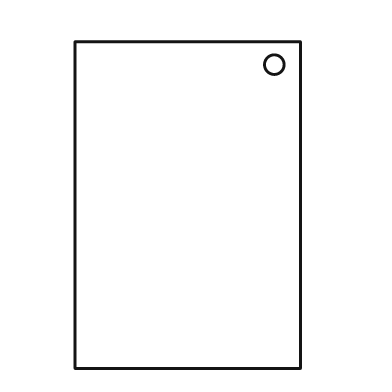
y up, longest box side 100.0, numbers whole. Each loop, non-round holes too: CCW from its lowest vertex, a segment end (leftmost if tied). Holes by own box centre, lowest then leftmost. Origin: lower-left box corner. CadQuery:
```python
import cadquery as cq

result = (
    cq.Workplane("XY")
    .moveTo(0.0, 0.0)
    .lineTo(69.0, 0.0)
    .lineTo(69.0, 100.0)
    .lineTo(0.0, 100.0)
    .close()
    .moveTo(61.0, 93.0)
    .circle(3.0)
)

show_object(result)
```